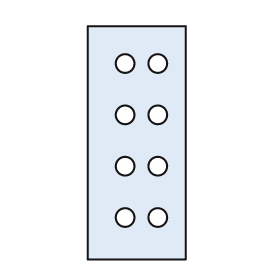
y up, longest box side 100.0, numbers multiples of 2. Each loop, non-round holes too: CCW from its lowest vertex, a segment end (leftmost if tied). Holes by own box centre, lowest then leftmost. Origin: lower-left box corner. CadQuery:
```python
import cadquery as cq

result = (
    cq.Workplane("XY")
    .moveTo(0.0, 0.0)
    .lineTo(42.0, 0.0)
    .lineTo(42.0, 100.0)
    .lineTo(0.0, 100.0)
    .close()
    .moveTo(16.0, 18.0)
    .circle(4.0)
    .moveTo(30.0, 18.0)
    .circle(4.0)
    .moveTo(16.0, 40.0)
    .circle(4.0)
    .moveTo(30.0, 40.0)
    .circle(4.0)
    .moveTo(16.0, 62.0)
    .circle(4.0)
    .moveTo(30.0, 62.0)
    .circle(4.0)
    .moveTo(16.0, 84.0)
    .circle(4.0)
    .moveTo(30.0, 84.0)
    .circle(4.0)
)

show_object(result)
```